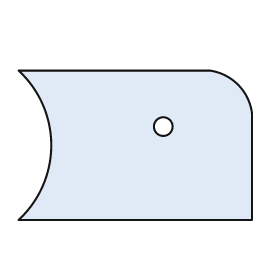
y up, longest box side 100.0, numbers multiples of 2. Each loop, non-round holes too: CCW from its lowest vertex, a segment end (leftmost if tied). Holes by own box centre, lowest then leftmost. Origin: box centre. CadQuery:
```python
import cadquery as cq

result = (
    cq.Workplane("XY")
    .moveTo(-50.0, -32.0)
    .lineTo(50.0, -32.0)
    .lineTo(50.0, 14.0)
    .threePointArc((44.0, 26.0), (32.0, 32.0))
    .lineTo(-50.0, 32.0)
    .threePointArc((-36.0, 0.0), (-50.0, -32.0))
    .close()
    .moveTo(12.0, 8.0)
    .circle(4.0)
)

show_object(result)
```